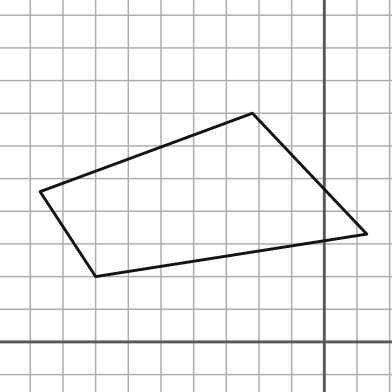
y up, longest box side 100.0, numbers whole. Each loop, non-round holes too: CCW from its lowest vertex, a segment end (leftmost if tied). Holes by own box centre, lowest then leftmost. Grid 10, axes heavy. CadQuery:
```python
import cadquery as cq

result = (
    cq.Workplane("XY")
    .moveTo(-70.0, 20.0)
    .lineTo(13.0, 33.0)
    .lineTo(-22.0, 70.0)
    .lineTo(-87.0, 46.0)
    .close()
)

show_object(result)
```